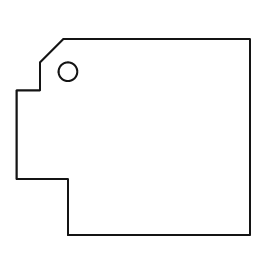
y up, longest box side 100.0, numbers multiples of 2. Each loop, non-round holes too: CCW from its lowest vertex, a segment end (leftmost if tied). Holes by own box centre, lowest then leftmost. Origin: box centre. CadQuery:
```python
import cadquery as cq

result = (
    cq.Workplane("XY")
    .moveTo(-28.0, -42.0)
    .lineTo(50.0, -42.0)
    .lineTo(50.0, 42.0)
    .lineTo(-30.0, 42.0)
    .lineTo(-40.0, 32.0)
    .lineTo(-40.0, 20.0)
    .lineTo(-50.0, 20.0)
    .lineTo(-50.0, -18.0)
    .lineTo(-28.0, -18.0)
    .close()
    .moveTo(-28.0, 28.0)
    .circle(4.0)
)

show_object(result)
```